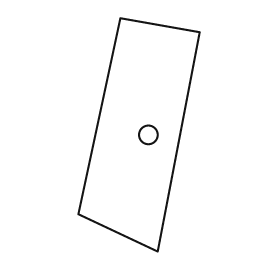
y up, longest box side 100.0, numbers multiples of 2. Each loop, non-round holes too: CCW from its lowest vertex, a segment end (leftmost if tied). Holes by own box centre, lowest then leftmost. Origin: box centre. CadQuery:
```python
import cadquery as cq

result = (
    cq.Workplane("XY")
    .moveTo(8.0, -50.0)
    .lineTo(26.0, 44.0)
    .lineTo(-8.0, 50.0)
    .lineTo(-26.0, -34.0)
    .close()
    .moveTo(4.0, 0.0)
    .circle(4.0)
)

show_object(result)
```